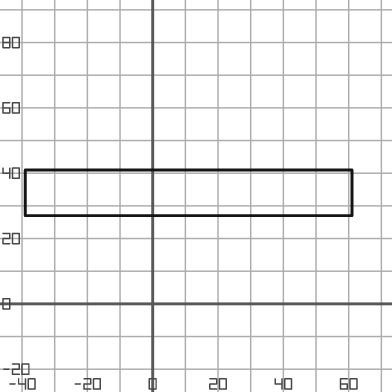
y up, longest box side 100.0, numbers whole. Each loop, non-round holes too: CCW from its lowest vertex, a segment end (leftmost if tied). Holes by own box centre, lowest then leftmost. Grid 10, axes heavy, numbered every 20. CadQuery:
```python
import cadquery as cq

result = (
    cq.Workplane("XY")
    .moveTo(-39.0, 27.0)
    .lineTo(61.0, 27.0)
    .lineTo(61.0, 41.0)
    .lineTo(-39.0, 41.0)
    .close()
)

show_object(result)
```